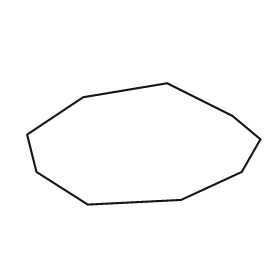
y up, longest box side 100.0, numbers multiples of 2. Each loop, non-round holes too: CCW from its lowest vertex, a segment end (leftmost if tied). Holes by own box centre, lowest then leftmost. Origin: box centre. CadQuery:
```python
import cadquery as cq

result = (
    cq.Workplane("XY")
    .moveTo(-24.0, -26.0)
    .lineTo(16.0, -24.0)
    .lineTo(42.0, -12.0)
    .lineTo(50.0, 2.0)
    .lineTo(38.0, 12.0)
    .lineTo(10.0, 26.0)
    .lineTo(-26.0, 20.0)
    .lineTo(-50.0, 4.0)
    .lineTo(-46.0, -12.0)
    .close()
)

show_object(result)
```